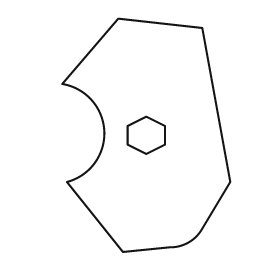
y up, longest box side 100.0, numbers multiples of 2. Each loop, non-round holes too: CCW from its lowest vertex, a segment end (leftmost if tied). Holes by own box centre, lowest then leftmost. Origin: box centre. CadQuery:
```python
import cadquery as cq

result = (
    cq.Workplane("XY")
    .moveTo(-10.0, -50.0)
    .lineTo(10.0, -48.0)
    .threePointArc((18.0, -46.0), (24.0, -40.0))
    .lineTo(36.0, -20.0)
    .lineTo(24.0, 46.0)
    .lineTo(-12.0, 50.0)
    .lineTo(-36.0, 22.0)
    .threePointArc((-18.0, 2.0), (-34.0, -20.0))
    .close()
    .moveTo(0.0, -8.0)
    .lineTo(8.0, -4.0)
    .lineTo(8.0, 4.0)
    .lineTo(0.0, 8.0)
    .lineTo(-8.0, 4.0)
    .lineTo(-8.0, -4.0)
    .close()
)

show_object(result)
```